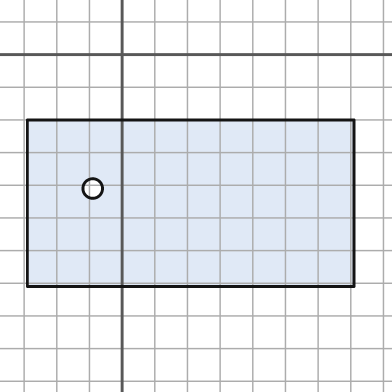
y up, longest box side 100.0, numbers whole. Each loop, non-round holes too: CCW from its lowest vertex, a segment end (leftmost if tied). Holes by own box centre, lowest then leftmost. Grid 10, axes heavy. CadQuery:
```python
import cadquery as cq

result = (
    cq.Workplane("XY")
    .moveTo(-29.0, -71.0)
    .lineTo(71.0, -71.0)
    .lineTo(71.0, -20.0)
    .lineTo(-29.0, -20.0)
    .close()
    .moveTo(-9.0, -41.0)
    .circle(3.0)
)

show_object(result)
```